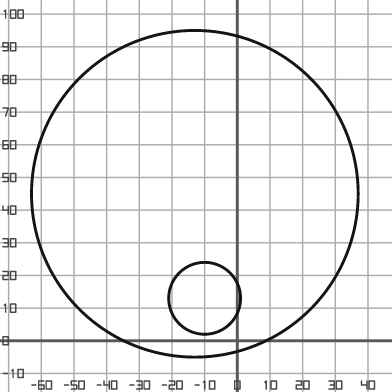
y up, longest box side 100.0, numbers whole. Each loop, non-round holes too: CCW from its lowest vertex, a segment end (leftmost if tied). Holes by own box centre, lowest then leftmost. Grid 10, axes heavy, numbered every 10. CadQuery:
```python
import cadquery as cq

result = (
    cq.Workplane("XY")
    .moveTo(-13.0, 45.0)
    .circle(50.0)
    .moveTo(-10.0, 13.0)
    .circle(11.0)
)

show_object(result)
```